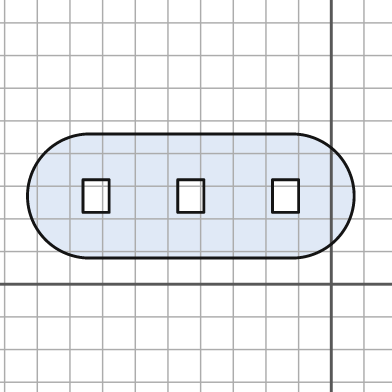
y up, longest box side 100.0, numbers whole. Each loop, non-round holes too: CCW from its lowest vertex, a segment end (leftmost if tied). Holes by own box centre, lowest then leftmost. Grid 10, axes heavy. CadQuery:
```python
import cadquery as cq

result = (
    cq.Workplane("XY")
    .moveTo(-74.0, 8.0)
    .lineTo(-12.0, 8.0)
    .threePointArc((7.0, 27.0), (-12.0, 46.0))
    .lineTo(-74.0, 46.0)
    .threePointArc((-93.0, 27.0), (-74.0, 8.0))
    .close()
    .moveTo(-76.0, 22.0)
    .lineTo(-68.0, 22.0)
    .lineTo(-68.0, 32.0)
    .lineTo(-76.0, 32.0)
    .close()
    .moveTo(-47.0, 22.0)
    .lineTo(-39.0, 22.0)
    .lineTo(-39.0, 32.0)
    .lineTo(-47.0, 32.0)
    .close()
    .moveTo(-18.0, 22.0)
    .lineTo(-10.0, 22.0)
    .lineTo(-10.0, 32.0)
    .lineTo(-18.0, 32.0)
    .close()
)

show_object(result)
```